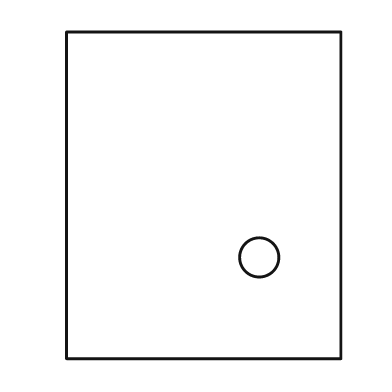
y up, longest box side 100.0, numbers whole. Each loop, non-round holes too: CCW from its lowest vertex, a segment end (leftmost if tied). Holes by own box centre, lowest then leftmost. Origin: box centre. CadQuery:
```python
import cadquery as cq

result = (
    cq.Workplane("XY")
    .moveTo(-42.0, -50.0)
    .lineTo(42.0, -50.0)
    .lineTo(42.0, 50.0)
    .lineTo(-42.0, 50.0)
    .close()
    .moveTo(17.0, -19.0)
    .circle(6.0)
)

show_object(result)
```